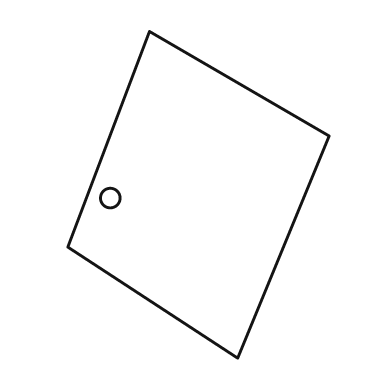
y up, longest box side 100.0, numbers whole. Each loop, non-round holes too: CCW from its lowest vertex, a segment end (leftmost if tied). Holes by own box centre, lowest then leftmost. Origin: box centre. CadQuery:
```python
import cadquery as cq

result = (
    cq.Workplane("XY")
    .moveTo(12.0, -50.0)
    .lineTo(40.0, 18.0)
    .lineTo(-15.0, 50.0)
    .lineTo(-40.0, -16.0)
    .close()
    .moveTo(-27.0, -1.0)
    .circle(3.0)
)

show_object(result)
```